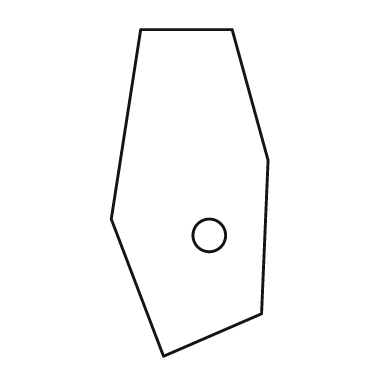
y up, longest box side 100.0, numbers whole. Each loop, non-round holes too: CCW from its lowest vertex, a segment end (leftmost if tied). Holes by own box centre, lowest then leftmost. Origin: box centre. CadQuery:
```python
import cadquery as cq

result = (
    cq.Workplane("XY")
    .moveTo(-8.0, -50.0)
    .lineTo(22.0, -37.0)
    .lineTo(24.0, 10.0)
    .lineTo(13.0, 50.0)
    .lineTo(-15.0, 50.0)
    .lineTo(-24.0, -8.0)
    .close()
    .moveTo(6.0, -13.0)
    .circle(5.0)
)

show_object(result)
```